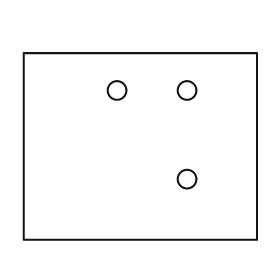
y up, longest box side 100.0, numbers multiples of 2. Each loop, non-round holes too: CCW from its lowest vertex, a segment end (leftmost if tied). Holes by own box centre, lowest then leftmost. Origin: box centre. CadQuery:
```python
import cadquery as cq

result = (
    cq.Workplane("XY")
    .moveTo(-50.0, -40.0)
    .lineTo(50.0, -40.0)
    .lineTo(50.0, 40.0)
    .lineTo(-50.0, 40.0)
    .close()
    .moveTo(20.0, -14.0)
    .circle(4.0)
    .moveTo(-10.0, 24.0)
    .circle(4.0)
    .moveTo(20.0, 24.0)
    .circle(4.0)
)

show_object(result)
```